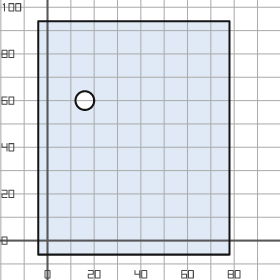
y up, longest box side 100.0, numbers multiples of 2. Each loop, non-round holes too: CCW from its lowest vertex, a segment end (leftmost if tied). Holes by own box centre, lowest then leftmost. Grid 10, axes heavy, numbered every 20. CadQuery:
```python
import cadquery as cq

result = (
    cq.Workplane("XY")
    .moveTo(-4.0, -6.0)
    .lineTo(78.0, -6.0)
    .lineTo(78.0, 94.0)
    .lineTo(-4.0, 94.0)
    .close()
    .moveTo(16.0, 60.0)
    .circle(4.0)
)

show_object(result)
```